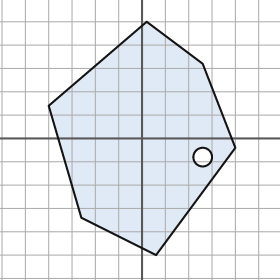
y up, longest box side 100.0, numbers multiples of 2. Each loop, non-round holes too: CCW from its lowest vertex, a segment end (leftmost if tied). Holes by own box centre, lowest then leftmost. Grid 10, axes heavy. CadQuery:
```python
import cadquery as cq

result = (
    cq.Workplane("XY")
    .moveTo(6.0, -50.0)
    .lineTo(40.0, -4.0)
    .lineTo(26.0, 32.0)
    .lineTo(2.0, 50.0)
    .lineTo(-40.0, 14.0)
    .lineTo(-26.0, -34.0)
    .close()
    .moveTo(26.0, -8.0)
    .circle(4.0)
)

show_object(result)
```